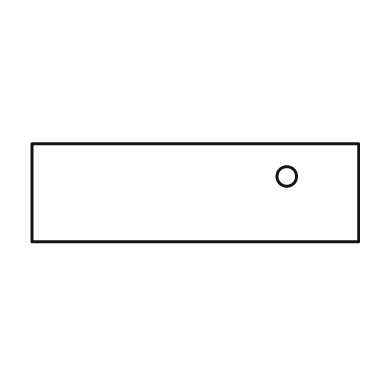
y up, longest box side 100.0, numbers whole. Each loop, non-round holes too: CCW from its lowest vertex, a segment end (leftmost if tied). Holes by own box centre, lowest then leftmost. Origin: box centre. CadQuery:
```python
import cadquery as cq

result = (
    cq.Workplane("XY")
    .moveTo(-50.0, -15.0)
    .lineTo(50.0, -15.0)
    .lineTo(50.0, 15.0)
    .lineTo(-50.0, 15.0)
    .close()
    .moveTo(28.0, 5.0)
    .circle(3.0)
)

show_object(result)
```